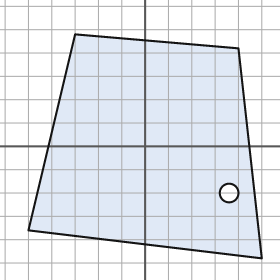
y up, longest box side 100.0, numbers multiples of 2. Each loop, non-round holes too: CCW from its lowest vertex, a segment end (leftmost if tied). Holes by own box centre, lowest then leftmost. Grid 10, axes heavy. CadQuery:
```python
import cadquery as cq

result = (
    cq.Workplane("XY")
    .moveTo(50.0, -48.0)
    .lineTo(40.0, 42.0)
    .lineTo(-30.0, 48.0)
    .lineTo(-50.0, -36.0)
    .close()
    .moveTo(36.0, -20.0)
    .circle(4.0)
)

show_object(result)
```